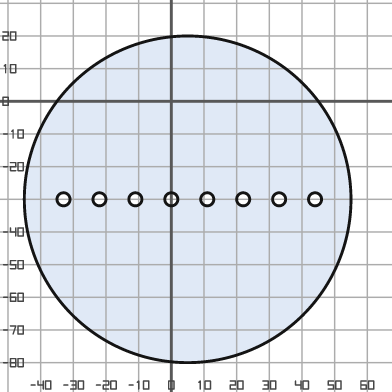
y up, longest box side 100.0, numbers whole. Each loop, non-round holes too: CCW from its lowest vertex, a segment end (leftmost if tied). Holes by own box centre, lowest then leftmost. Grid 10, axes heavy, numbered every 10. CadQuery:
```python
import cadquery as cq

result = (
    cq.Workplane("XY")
    .moveTo(5.0, -30.0)
    .circle(50.0)
    .moveTo(-33.0, -30.0)
    .circle(2.0)
    .moveTo(-22.0, -30.0)
    .circle(2.0)
    .moveTo(-11.0, -30.0)
    .circle(2.0)
    .moveTo(0.0, -30.0)
    .circle(2.0)
    .moveTo(11.0, -30.0)
    .circle(2.0)
    .moveTo(22.0, -30.0)
    .circle(2.0)
    .moveTo(33.0, -30.0)
    .circle(2.0)
    .moveTo(44.0, -30.0)
    .circle(2.0)
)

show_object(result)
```